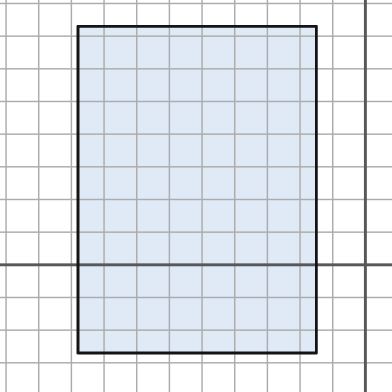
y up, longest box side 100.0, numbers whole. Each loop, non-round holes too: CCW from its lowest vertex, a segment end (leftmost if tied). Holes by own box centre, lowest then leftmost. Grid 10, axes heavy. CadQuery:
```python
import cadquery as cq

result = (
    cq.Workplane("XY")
    .moveTo(-88.0, -27.0)
    .lineTo(-15.0, -27.0)
    .lineTo(-15.0, 73.0)
    .lineTo(-88.0, 73.0)
    .close()
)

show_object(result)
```